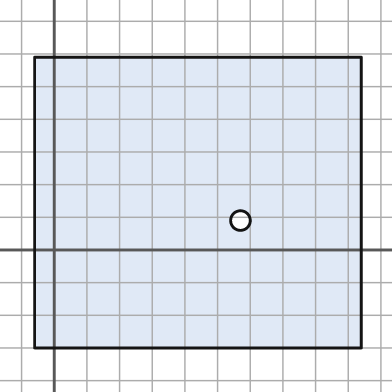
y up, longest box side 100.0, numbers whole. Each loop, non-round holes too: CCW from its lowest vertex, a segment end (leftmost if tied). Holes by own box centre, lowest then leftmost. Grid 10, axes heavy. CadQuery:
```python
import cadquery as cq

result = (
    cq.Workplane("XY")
    .moveTo(-6.0, -30.0)
    .lineTo(94.0, -30.0)
    .lineTo(94.0, 59.0)
    .lineTo(-6.0, 59.0)
    .close()
    .moveTo(57.0, 9.0)
    .circle(3.0)
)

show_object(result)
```